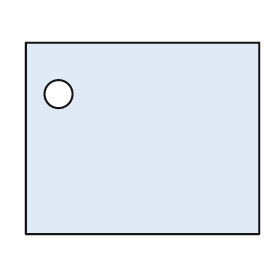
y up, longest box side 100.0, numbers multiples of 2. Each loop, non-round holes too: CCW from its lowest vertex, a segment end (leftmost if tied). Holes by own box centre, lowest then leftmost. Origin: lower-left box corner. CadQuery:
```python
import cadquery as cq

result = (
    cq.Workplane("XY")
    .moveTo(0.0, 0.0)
    .lineTo(100.0, 0.0)
    .lineTo(100.0, 82.0)
    .lineTo(0.0, 82.0)
    .close()
    .moveTo(14.0, 60.0)
    .circle(6.0)
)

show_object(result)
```